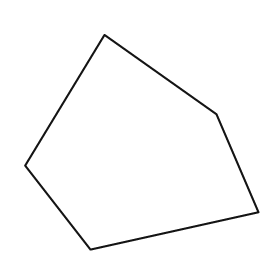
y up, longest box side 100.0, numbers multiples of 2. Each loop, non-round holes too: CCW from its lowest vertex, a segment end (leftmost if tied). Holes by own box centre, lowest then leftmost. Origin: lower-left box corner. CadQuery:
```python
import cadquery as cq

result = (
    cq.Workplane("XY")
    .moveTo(28.0, 0.0)
    .lineTo(100.0, 16.0)
    .lineTo(82.0, 58.0)
    .lineTo(34.0, 92.0)
    .lineTo(0.0, 36.0)
    .close()
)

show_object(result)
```